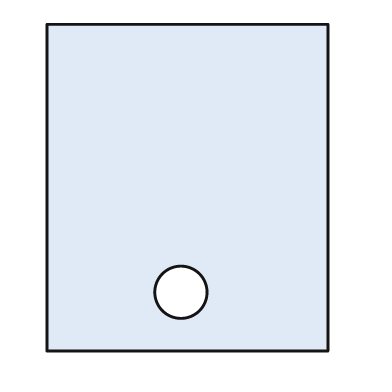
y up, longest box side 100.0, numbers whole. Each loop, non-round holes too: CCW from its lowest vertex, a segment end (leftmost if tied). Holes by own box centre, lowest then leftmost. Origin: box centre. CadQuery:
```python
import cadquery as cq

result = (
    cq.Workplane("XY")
    .moveTo(-43.0, -50.0)
    .lineTo(43.0, -50.0)
    .lineTo(43.0, 50.0)
    .lineTo(-43.0, 50.0)
    .close()
    .moveTo(-2.0, -32.0)
    .circle(8.0)
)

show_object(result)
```